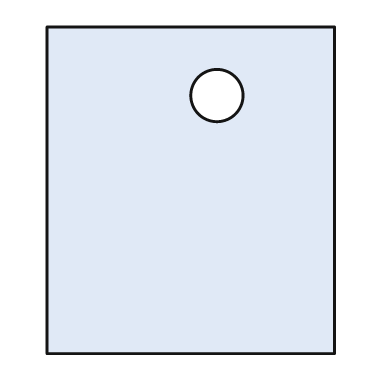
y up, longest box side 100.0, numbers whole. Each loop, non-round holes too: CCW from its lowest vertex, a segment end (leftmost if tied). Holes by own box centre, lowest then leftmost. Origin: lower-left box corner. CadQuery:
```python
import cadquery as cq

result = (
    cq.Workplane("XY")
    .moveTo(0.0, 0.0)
    .lineTo(88.0, 0.0)
    .lineTo(88.0, 100.0)
    .lineTo(0.0, 100.0)
    .close()
    .moveTo(52.0, 79.0)
    .circle(8.0)
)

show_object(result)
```